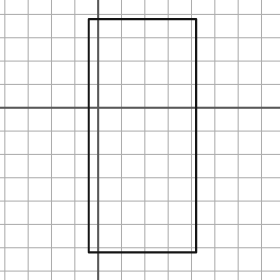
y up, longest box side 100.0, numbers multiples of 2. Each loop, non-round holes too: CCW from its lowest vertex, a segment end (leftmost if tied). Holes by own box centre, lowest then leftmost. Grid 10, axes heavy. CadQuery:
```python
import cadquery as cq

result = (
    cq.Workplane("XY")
    .moveTo(-4.0, -62.0)
    .lineTo(42.0, -62.0)
    .lineTo(42.0, 38.0)
    .lineTo(-4.0, 38.0)
    .close()
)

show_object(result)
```